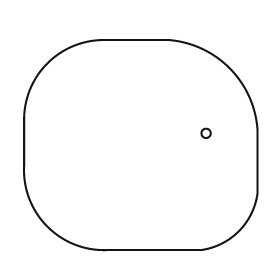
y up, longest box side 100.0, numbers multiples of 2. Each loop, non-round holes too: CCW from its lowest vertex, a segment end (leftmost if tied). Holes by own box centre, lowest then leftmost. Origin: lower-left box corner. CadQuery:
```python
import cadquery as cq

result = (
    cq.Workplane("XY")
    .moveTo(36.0, 0.0)
    .lineTo(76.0, 0.0)
    .threePointArc((92.0, 8.0), (100.0, 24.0))
    .lineTo(100.0, 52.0)
    .threePointArc((88.0, 78.0), (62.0, 90.0))
    .lineTo(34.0, 90.0)
    .threePointArc((10.0, 80.0), (0.0, 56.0))
    .lineTo(0.0, 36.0)
    .threePointArc((10.0, 10.0), (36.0, 0.0))
    .close()
    .moveTo(78.0, 50.0)
    .circle(2.0)
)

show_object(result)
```